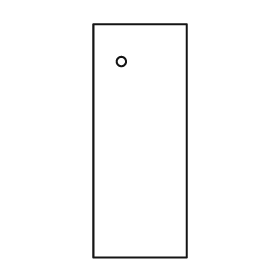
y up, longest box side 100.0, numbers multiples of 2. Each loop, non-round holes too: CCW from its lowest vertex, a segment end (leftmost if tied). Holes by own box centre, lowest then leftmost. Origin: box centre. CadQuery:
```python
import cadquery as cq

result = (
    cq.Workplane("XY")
    .moveTo(-20.0, -50.0)
    .lineTo(20.0, -50.0)
    .lineTo(20.0, 50.0)
    .lineTo(-20.0, 50.0)
    .close()
    .moveTo(-8.0, 34.0)
    .circle(2.0)
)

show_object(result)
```